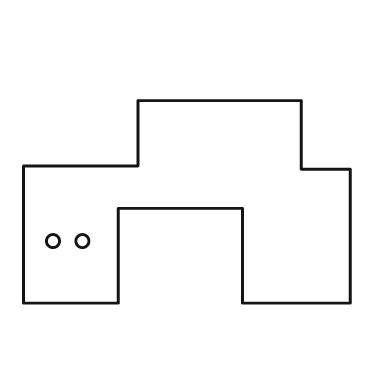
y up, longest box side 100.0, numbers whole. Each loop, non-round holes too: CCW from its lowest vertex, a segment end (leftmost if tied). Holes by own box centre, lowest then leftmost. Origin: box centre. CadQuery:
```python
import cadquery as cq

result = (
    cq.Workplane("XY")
    .moveTo(-50.0, -31.0)
    .lineTo(-21.0, -31.0)
    .lineTo(-21.0, -2.0)
    .lineTo(17.0, -2.0)
    .lineTo(17.0, -31.0)
    .lineTo(50.0, -31.0)
    .lineTo(50.0, 10.0)
    .lineTo(35.0, 10.0)
    .lineTo(35.0, 31.0)
    .lineTo(-15.0, 31.0)
    .lineTo(-15.0, 11.0)
    .lineTo(-50.0, 11.0)
    .close()
    .moveTo(-41.0, -12.0)
    .circle(2.0)
    .moveTo(-32.0, -12.0)
    .circle(2.0)
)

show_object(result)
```